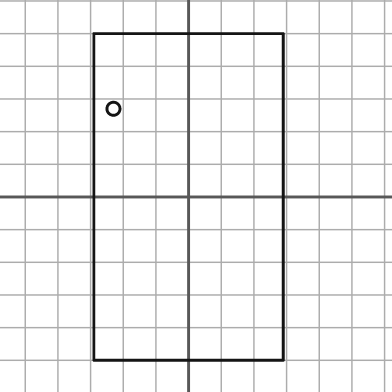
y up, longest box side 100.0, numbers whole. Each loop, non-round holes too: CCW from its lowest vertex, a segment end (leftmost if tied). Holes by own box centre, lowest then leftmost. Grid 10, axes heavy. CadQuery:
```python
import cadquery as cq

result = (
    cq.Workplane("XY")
    .moveTo(-29.0, -50.0)
    .lineTo(29.0, -50.0)
    .lineTo(29.0, 50.0)
    .lineTo(-29.0, 50.0)
    .close()
    .moveTo(-23.0, 27.0)
    .circle(2.0)
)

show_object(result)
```